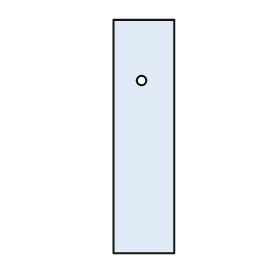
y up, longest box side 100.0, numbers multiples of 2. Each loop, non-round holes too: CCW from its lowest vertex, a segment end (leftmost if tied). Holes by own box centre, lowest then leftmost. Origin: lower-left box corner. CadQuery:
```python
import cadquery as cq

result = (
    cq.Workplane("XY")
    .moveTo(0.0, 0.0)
    .lineTo(26.0, 0.0)
    .lineTo(26.0, 100.0)
    .lineTo(0.0, 100.0)
    .close()
    .moveTo(12.0, 74.0)
    .circle(2.0)
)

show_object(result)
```